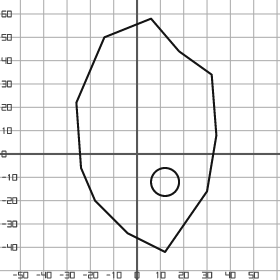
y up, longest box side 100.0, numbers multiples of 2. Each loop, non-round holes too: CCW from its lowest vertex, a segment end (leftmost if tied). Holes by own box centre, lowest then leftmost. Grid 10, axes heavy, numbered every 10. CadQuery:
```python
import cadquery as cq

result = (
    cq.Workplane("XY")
    .moveTo(12.0, -42.0)
    .lineTo(30.0, -16.0)
    .lineTo(34.0, 8.0)
    .lineTo(32.0, 34.0)
    .lineTo(18.0, 44.0)
    .lineTo(6.0, 58.0)
    .lineTo(-14.0, 50.0)
    .lineTo(-26.0, 22.0)
    .lineTo(-24.0, -6.0)
    .lineTo(-18.0, -20.0)
    .lineTo(-4.0, -34.0)
    .close()
    .moveTo(12.0, -12.0)
    .circle(6.0)
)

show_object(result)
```